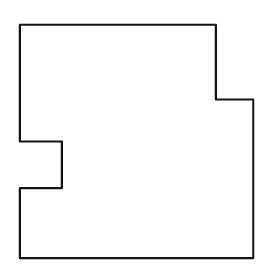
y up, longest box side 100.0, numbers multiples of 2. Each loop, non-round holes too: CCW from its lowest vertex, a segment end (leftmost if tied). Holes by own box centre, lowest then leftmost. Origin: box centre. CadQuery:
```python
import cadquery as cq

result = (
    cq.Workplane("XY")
    .moveTo(-50.0, -50.0)
    .lineTo(50.0, -50.0)
    .lineTo(50.0, 18.0)
    .lineTo(34.0, 18.0)
    .lineTo(34.0, 50.0)
    .lineTo(-50.0, 50.0)
    .lineTo(-50.0, 0.0)
    .lineTo(-32.0, 0.0)
    .lineTo(-32.0, -20.0)
    .lineTo(-50.0, -20.0)
    .close()
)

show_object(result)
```